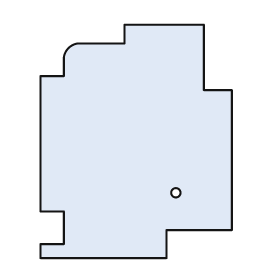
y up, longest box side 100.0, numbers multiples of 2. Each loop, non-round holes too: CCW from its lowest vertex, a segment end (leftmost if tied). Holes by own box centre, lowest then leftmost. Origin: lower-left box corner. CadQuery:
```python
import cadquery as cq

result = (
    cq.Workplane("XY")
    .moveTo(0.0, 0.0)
    .lineTo(54.0, 0.0)
    .lineTo(54.0, 12.0)
    .lineTo(82.0, 12.0)
    .lineTo(82.0, 72.0)
    .lineTo(70.0, 72.0)
    .lineTo(70.0, 100.0)
    .lineTo(36.0, 100.0)
    .lineTo(36.0, 92.0)
    .lineTo(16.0, 92.0)
    .threePointArc((12.0, 90.0), (10.0, 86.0))
    .lineTo(10.0, 78.0)
    .lineTo(0.0, 78.0)
    .lineTo(0.0, 20.0)
    .lineTo(10.0, 20.0)
    .lineTo(10.0, 6.0)
    .lineTo(0.0, 6.0)
    .close()
    .moveTo(58.0, 28.0)
    .circle(2.0)
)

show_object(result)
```